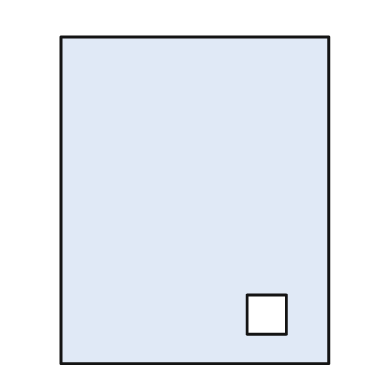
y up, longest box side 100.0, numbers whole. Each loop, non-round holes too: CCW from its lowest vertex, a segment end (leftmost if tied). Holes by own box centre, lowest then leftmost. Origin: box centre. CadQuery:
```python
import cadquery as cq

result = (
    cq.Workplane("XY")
    .moveTo(-41.0, -50.0)
    .lineTo(41.0, -50.0)
    .lineTo(41.0, 50.0)
    .lineTo(-41.0, 50.0)
    .close()
    .moveTo(16.0, -41.0)
    .lineTo(28.0, -41.0)
    .lineTo(28.0, -29.0)
    .lineTo(16.0, -29.0)
    .close()
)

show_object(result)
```